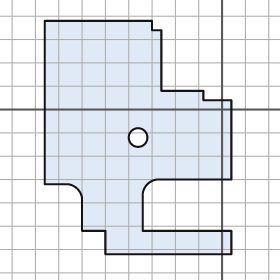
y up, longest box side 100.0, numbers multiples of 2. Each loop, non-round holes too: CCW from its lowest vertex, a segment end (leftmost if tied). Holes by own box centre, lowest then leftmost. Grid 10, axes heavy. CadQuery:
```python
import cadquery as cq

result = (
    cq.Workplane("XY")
    .moveTo(-50.0, -62.0)
    .lineTo(4.0, -62.0)
    .lineTo(4.0, -52.0)
    .lineTo(-34.0, -52.0)
    .lineTo(-34.0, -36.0)
    .threePointArc((-32.0, -32.0), (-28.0, -30.0))
    .lineTo(4.0, -30.0)
    .lineTo(4.0, 4.0)
    .lineTo(-8.0, 4.0)
    .lineTo(-8.0, 8.0)
    .lineTo(-26.0, 8.0)
    .lineTo(-26.0, 34.0)
    .lineTo(-30.0, 34.0)
    .lineTo(-30.0, 38.0)
    .lineTo(-76.0, 38.0)
    .lineTo(-76.0, -32.0)
    .lineTo(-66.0, -32.0)
    .threePointArc((-62.0, -34.0), (-60.0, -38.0))
    .lineTo(-60.0, -52.0)
    .lineTo(-50.0, -52.0)
    .close()
    .moveTo(-36.0, -12.0)
    .circle(4.0)
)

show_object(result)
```